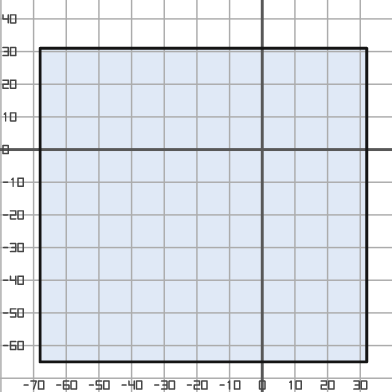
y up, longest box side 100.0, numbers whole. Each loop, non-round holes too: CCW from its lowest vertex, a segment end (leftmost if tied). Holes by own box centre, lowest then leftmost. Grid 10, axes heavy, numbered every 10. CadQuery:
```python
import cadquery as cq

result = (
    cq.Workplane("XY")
    .moveTo(-68.0, -65.0)
    .lineTo(32.0, -65.0)
    .lineTo(32.0, 31.0)
    .lineTo(-68.0, 31.0)
    .close()
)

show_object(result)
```